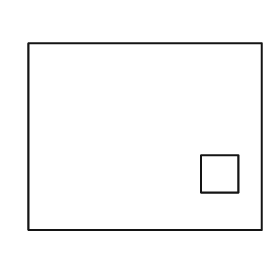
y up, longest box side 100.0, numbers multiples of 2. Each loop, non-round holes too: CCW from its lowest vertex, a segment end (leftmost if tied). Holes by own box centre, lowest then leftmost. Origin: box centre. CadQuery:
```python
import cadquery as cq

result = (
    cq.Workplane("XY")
    .moveTo(-50.0, -40.0)
    .lineTo(50.0, -40.0)
    .lineTo(50.0, 40.0)
    .lineTo(-50.0, 40.0)
    .close()
    .moveTo(24.0, -24.0)
    .lineTo(40.0, -24.0)
    .lineTo(40.0, -8.0)
    .lineTo(24.0, -8.0)
    .close()
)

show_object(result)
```